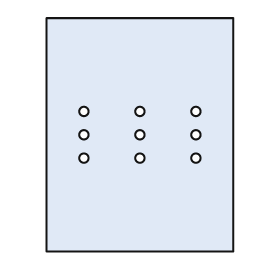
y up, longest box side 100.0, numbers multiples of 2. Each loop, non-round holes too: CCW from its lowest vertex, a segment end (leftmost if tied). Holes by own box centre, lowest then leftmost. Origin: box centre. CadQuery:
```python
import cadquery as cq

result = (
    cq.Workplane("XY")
    .moveTo(-40.0, -50.0)
    .lineTo(40.0, -50.0)
    .lineTo(40.0, 50.0)
    .lineTo(-40.0, 50.0)
    .close()
    .moveTo(-24.0, -10.0)
    .circle(2.0)
    .moveTo(0.0, -10.0)
    .circle(2.0)
    .moveTo(24.0, -10.0)
    .circle(2.0)
    .moveTo(-24.0, 0.0)
    .circle(2.0)
    .moveTo(0.0, 0.0)
    .circle(2.0)
    .moveTo(24.0, 0.0)
    .circle(2.0)
    .moveTo(-24.0, 10.0)
    .circle(2.0)
    .moveTo(0.0, 10.0)
    .circle(2.0)
    .moveTo(24.0, 10.0)
    .circle(2.0)
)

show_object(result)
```